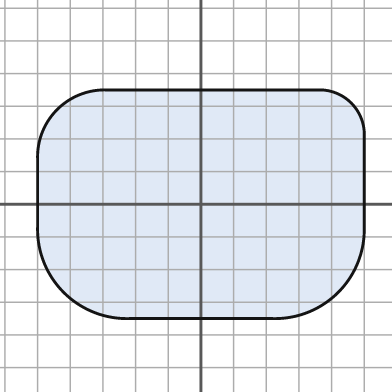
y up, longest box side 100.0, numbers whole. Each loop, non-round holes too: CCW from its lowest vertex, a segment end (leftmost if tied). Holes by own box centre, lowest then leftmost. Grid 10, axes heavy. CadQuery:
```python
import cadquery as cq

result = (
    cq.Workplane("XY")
    .moveTo(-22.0, -35.0)
    .lineTo(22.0, -35.0)
    .threePointArc((42.0, -27.0), (50.0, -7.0))
    .lineTo(50.0, 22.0)
    .threePointArc((46.0, 31.0), (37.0, 35.0))
    .lineTo(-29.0, 35.0)
    .threePointArc((-44.0, 29.0), (-50.0, 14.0))
    .lineTo(-50.0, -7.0)
    .threePointArc((-42.0, -27.0), (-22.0, -35.0))
    .close()
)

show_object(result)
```